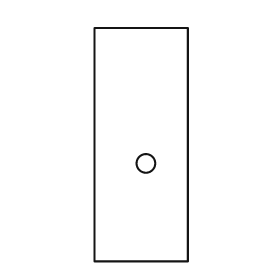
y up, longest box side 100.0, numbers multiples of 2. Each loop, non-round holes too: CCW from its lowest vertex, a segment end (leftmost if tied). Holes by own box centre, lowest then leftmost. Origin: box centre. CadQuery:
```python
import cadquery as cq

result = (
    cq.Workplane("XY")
    .moveTo(-20.0, -50.0)
    .lineTo(20.0, -50.0)
    .lineTo(20.0, 50.0)
    .lineTo(-20.0, 50.0)
    .close()
    .moveTo(2.0, -8.0)
    .circle(4.0)
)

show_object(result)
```